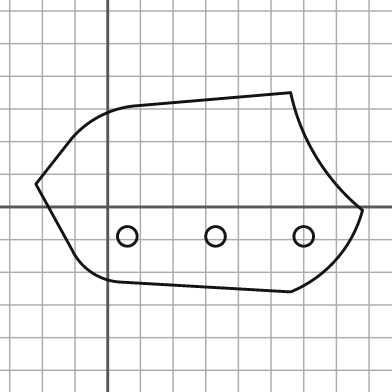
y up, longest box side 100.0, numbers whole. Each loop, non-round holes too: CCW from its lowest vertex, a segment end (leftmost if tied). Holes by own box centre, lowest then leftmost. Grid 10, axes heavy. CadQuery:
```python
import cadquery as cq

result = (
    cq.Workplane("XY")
    .moveTo(56.0, -26.0)
    .threePointArc((70.0, -16.0), (78.0, -1.0))
    .threePointArc((64.0, 15.0), (56.0, 35.0))
    .lineTo(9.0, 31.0)
    .threePointArc((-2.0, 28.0), (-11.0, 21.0))
    .lineTo(-22.0, 7.0)
    .lineTo(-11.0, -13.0)
    .threePointArc((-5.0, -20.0), (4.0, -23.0))
    .close()
    .moveTo(6.0, -9.0)
    .circle(3.0)
    .moveTo(33.0, -9.0)
    .circle(3.0)
    .moveTo(60.0, -9.0)
    .circle(3.0)
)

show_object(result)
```